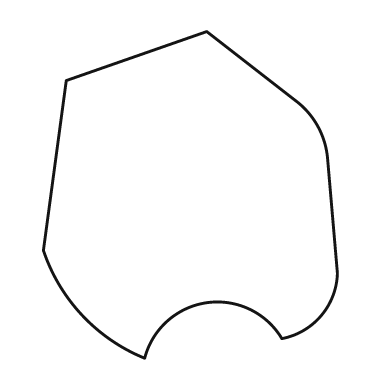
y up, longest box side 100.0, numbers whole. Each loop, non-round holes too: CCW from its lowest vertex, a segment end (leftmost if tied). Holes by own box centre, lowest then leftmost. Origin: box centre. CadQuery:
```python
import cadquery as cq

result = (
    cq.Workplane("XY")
    .moveTo(-14.0, -50.0)
    .threePointArc((5.0, -33.0), (28.0, -44.0))
    .threePointArc((40.0, -37.0), (45.0, -24.0))
    .lineTo(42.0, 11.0)
    .threePointArc((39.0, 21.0), (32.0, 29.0))
    .lineTo(5.0, 50.0)
    .lineTo(-38.0, 35.0)
    .lineTo(-45.0, -17.0)
    .threePointArc((-33.0, -37.0), (-14.0, -50.0))
    .close()
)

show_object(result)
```